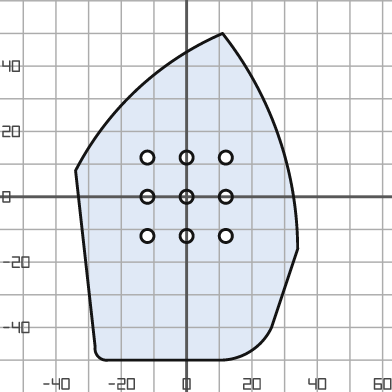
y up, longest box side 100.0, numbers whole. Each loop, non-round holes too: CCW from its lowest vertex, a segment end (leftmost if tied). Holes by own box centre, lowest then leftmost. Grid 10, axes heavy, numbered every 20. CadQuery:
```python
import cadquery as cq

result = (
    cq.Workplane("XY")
    .moveTo(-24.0, -50.0)
    .lineTo(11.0, -50.0)
    .threePointArc((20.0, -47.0), (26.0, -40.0))
    .lineTo(34.0, -16.0)
    .threePointArc((28.0, 19.0), (11.0, 50.0))
    .threePointArc((-15.0, 33.0), (-34.0, 8.0))
    .lineTo(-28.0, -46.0)
    .threePointArc((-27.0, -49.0), (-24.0, -50.0))
    .close()
    .moveTo(-12.0, -12.0)
    .circle(2.0)
    .moveTo(0.0, -12.0)
    .circle(2.0)
    .moveTo(12.0, -12.0)
    .circle(2.0)
    .moveTo(-12.0, 0.0)
    .circle(2.0)
    .moveTo(0.0, 0.0)
    .circle(2.0)
    .moveTo(12.0, 0.0)
    .circle(2.0)
    .moveTo(-12.0, 12.0)
    .circle(2.0)
    .moveTo(0.0, 12.0)
    .circle(2.0)
    .moveTo(12.0, 12.0)
    .circle(2.0)
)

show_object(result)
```